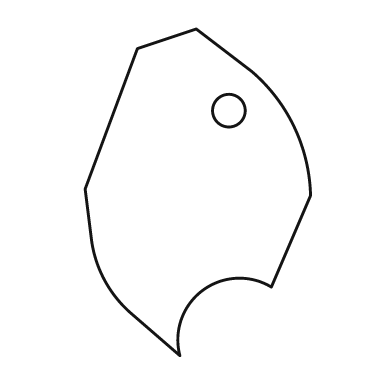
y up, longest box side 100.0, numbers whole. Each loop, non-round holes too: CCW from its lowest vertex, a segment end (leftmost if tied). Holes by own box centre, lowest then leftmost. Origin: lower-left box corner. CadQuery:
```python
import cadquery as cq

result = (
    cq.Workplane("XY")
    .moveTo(29.0, 0.0)
    .threePointArc((36.0, 20.0), (57.0, 21.0))
    .lineTo(69.0, 49.0)
    .threePointArc((64.0, 70.0), (51.0, 87.0))
    .lineTo(34.0, 100.0)
    .lineTo(16.0, 94.0)
    .lineTo(0.0, 51.0)
    .lineTo(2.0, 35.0)
    .threePointArc((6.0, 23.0), (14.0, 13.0))
    .close()
    .moveTo(44.0, 75.0)
    .circle(5.0)
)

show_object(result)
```